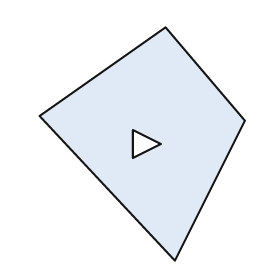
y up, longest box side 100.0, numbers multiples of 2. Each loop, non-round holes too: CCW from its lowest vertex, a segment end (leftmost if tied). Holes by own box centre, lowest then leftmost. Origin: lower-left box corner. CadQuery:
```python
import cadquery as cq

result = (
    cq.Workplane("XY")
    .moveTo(58.0, 0.0)
    .lineTo(88.0, 60.0)
    .lineTo(54.0, 100.0)
    .lineTo(0.0, 62.0)
    .close()
    .moveTo(40.0, 44.0)
    .lineTo(52.0, 50.0)
    .lineTo(40.0, 56.0)
    .close()
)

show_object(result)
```